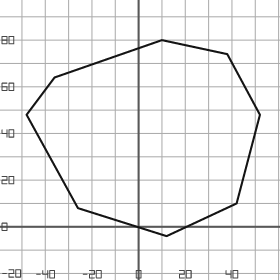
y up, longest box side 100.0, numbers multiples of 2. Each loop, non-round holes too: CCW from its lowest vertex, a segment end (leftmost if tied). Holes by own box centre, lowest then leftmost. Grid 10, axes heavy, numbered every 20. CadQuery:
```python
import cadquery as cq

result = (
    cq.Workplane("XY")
    .moveTo(12.0, -4.0)
    .lineTo(42.0, 10.0)
    .lineTo(52.0, 48.0)
    .lineTo(38.0, 74.0)
    .lineTo(10.0, 80.0)
    .lineTo(-36.0, 64.0)
    .lineTo(-48.0, 48.0)
    .lineTo(-26.0, 8.0)
    .close()
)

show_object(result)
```